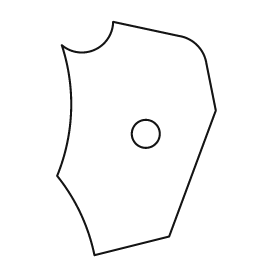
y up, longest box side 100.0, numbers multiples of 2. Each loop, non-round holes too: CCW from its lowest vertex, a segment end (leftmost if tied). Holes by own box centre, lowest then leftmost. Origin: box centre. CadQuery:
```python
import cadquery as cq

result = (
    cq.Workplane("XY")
    .moveTo(-18.0, -50.0)
    .lineTo(14.0, -42.0)
    .lineTo(34.0, 12.0)
    .lineTo(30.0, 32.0)
    .threePointArc((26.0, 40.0), (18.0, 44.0))
    .lineTo(-10.0, 50.0)
    .threePointArc((-18.0, 38.0), (-32.0, 40.0))
    .threePointArc((-28.0, 12.0), (-34.0, -16.0))
    .threePointArc((-24.0, -32.0), (-18.0, -50.0))
    .close()
    .moveTo(4.0, 2.0)
    .circle(6.0)
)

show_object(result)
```